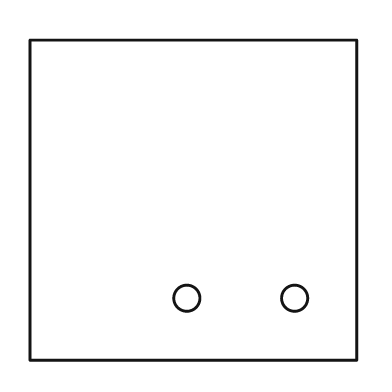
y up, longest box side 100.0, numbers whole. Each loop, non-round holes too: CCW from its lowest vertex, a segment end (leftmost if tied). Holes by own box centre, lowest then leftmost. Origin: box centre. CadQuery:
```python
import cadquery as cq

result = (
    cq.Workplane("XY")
    .moveTo(-50.0, -49.0)
    .lineTo(50.0, -49.0)
    .lineTo(50.0, 49.0)
    .lineTo(-50.0, 49.0)
    .close()
    .moveTo(-2.0, -30.0)
    .circle(4.0)
    .moveTo(31.0, -30.0)
    .circle(4.0)
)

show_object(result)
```